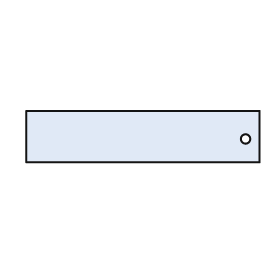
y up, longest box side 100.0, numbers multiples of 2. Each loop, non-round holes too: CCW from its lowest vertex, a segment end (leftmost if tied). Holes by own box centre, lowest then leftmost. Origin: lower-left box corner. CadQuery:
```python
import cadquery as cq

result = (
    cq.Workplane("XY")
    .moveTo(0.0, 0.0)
    .lineTo(100.0, 0.0)
    .lineTo(100.0, 22.0)
    .lineTo(0.0, 22.0)
    .close()
    .moveTo(94.0, 10.0)
    .circle(2.0)
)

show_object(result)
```